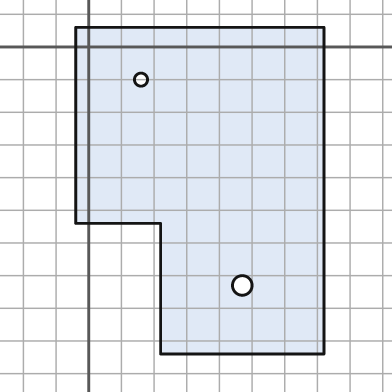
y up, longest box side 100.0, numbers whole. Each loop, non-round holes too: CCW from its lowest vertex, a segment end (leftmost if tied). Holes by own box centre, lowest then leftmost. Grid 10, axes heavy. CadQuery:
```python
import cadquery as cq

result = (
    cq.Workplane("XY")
    .moveTo(22.0, -94.0)
    .lineTo(72.0, -94.0)
    .lineTo(72.0, 6.0)
    .lineTo(-4.0, 6.0)
    .lineTo(-4.0, -54.0)
    .lineTo(22.0, -54.0)
    .close()
    .moveTo(47.0, -73.0)
    .circle(3.0)
    .moveTo(16.0, -10.0)
    .circle(2.0)
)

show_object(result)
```